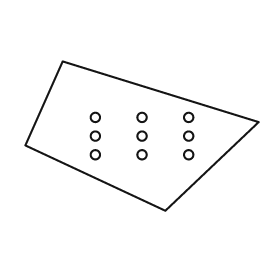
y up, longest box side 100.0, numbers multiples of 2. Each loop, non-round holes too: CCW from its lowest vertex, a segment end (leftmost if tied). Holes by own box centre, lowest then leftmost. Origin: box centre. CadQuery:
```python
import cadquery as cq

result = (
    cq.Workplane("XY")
    .moveTo(10.0, -32.0)
    .lineTo(50.0, 6.0)
    .lineTo(-34.0, 32.0)
    .lineTo(-50.0, -4.0)
    .close()
    .moveTo(-20.0, -8.0)
    .circle(2.0)
    .moveTo(0.0, -8.0)
    .circle(2.0)
    .moveTo(20.0, -8.0)
    .circle(2.0)
    .moveTo(-20.0, 0.0)
    .circle(2.0)
    .moveTo(0.0, 0.0)
    .circle(2.0)
    .moveTo(20.0, 0.0)
    .circle(2.0)
    .moveTo(-20.0, 8.0)
    .circle(2.0)
    .moveTo(0.0, 8.0)
    .circle(2.0)
    .moveTo(20.0, 8.0)
    .circle(2.0)
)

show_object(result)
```